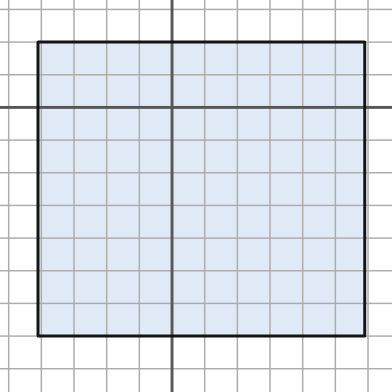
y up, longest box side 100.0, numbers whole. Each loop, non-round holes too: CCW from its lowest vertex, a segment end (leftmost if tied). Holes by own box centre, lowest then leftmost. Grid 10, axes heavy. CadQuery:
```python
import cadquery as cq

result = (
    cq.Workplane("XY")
    .moveTo(-41.0, -70.0)
    .lineTo(59.0, -70.0)
    .lineTo(59.0, 20.0)
    .lineTo(-41.0, 20.0)
    .close()
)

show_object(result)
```